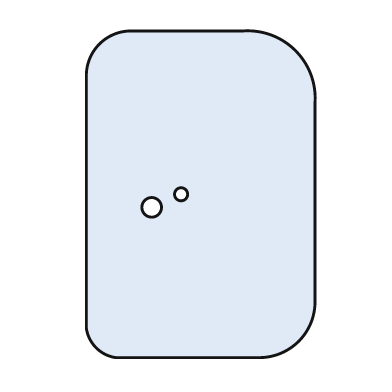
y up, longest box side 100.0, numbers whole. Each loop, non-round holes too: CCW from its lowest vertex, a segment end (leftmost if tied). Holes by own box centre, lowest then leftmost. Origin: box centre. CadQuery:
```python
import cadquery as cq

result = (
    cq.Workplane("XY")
    .moveTo(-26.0, -50.0)
    .lineTo(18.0, -50.0)
    .threePointArc((30.0, -45.0), (35.0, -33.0))
    .lineTo(35.0, 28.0)
    .threePointArc((29.0, 44.0), (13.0, 50.0))
    .lineTo(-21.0, 50.0)
    .threePointArc((-31.0, 46.0), (-35.0, 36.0))
    .lineTo(-35.0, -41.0)
    .threePointArc((-32.0, -47.0), (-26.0, -50.0))
    .close()
    .moveTo(-15.0, -4.0)
    .circle(3.0)
    .moveTo(-6.0, 0.0)
    .circle(2.0)
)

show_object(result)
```